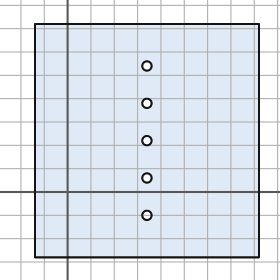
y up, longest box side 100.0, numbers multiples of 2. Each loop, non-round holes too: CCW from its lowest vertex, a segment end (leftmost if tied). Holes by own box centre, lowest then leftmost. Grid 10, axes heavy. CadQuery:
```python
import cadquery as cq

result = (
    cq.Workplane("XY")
    .moveTo(-14.0, -28.0)
    .lineTo(82.0, -28.0)
    .lineTo(82.0, 72.0)
    .lineTo(-14.0, 72.0)
    .close()
    .moveTo(34.0, -10.0)
    .circle(2.0)
    .moveTo(34.0, 6.0)
    .circle(2.0)
    .moveTo(34.0, 22.0)
    .circle(2.0)
    .moveTo(34.0, 38.0)
    .circle(2.0)
    .moveTo(34.0, 54.0)
    .circle(2.0)
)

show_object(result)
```